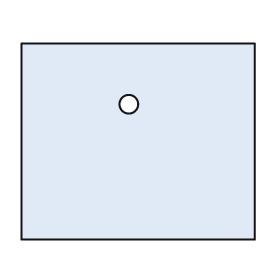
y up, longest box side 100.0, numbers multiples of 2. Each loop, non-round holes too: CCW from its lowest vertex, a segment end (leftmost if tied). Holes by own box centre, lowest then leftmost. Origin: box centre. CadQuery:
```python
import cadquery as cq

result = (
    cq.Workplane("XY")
    .moveTo(-50.0, -42.0)
    .lineTo(50.0, -42.0)
    .lineTo(50.0, 42.0)
    .lineTo(-50.0, 42.0)
    .close()
    .moveTo(-4.0, 16.0)
    .circle(4.0)
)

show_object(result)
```